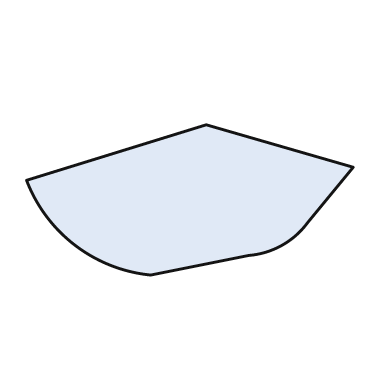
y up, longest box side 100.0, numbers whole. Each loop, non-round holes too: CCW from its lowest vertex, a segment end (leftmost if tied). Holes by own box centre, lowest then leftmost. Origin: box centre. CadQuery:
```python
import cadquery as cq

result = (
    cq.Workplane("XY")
    .moveTo(-12.0, -23.0)
    .lineTo(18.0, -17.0)
    .threePointArc((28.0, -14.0), (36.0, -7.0))
    .lineTo(50.0, 10.0)
    .lineTo(5.0, 23.0)
    .lineTo(-50.0, 6.0)
    .threePointArc((-35.0, -14.0), (-12.0, -23.0))
    .close()
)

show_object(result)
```